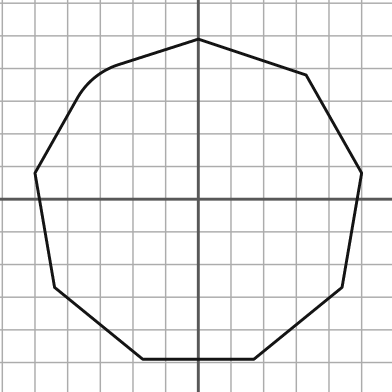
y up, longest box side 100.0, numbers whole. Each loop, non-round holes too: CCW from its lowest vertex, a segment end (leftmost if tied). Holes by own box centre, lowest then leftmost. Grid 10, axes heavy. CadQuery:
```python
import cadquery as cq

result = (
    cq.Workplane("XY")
    .moveTo(-17.0, -49.0)
    .lineTo(17.0, -49.0)
    .lineTo(44.0, -27.0)
    .lineTo(50.0, 8.0)
    .lineTo(33.0, 38.0)
    .lineTo(0.0, 49.0)
    .lineTo(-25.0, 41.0)
    .threePointArc((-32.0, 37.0), (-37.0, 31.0))
    .lineTo(-50.0, 8.0)
    .lineTo(-44.0, -27.0)
    .close()
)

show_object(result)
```